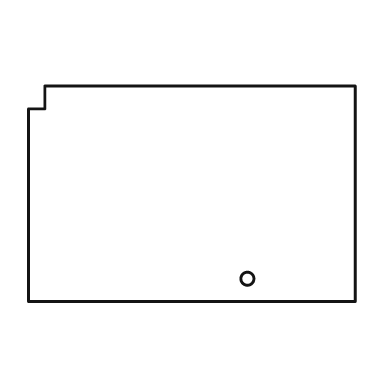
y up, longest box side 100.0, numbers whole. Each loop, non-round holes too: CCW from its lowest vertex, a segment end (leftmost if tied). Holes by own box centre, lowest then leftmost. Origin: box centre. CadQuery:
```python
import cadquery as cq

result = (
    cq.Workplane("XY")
    .moveTo(-50.0, -33.0)
    .lineTo(50.0, -33.0)
    .lineTo(50.0, 33.0)
    .lineTo(-45.0, 33.0)
    .lineTo(-45.0, 26.0)
    .lineTo(-50.0, 26.0)
    .close()
    .moveTo(17.0, -26.0)
    .circle(2.0)
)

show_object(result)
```